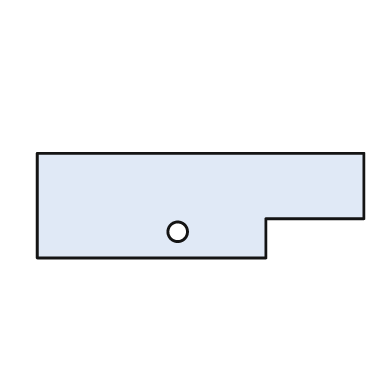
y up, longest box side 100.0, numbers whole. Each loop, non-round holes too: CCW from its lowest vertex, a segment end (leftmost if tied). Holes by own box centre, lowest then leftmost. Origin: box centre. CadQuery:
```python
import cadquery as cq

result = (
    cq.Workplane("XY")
    .moveTo(-50.0, -16.0)
    .lineTo(20.0, -16.0)
    .lineTo(20.0, -4.0)
    .lineTo(50.0, -4.0)
    .lineTo(50.0, 16.0)
    .lineTo(-50.0, 16.0)
    .close()
    .moveTo(-7.0, -8.0)
    .circle(3.0)
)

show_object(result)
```